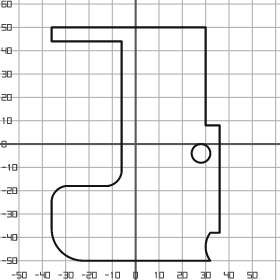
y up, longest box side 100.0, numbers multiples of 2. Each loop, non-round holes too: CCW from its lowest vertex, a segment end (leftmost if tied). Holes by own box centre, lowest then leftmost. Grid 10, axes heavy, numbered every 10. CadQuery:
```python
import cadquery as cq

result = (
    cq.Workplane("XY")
    .moveTo(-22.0, -50.0)
    .lineTo(32.0, -50.0)
    .threePointArc((30.0, -44.0), (32.0, -38.0))
    .lineTo(36.0, -38.0)
    .lineTo(36.0, 8.0)
    .lineTo(30.0, 8.0)
    .lineTo(30.0, 50.0)
    .lineTo(-36.0, 50.0)
    .lineTo(-36.0, 44.0)
    .lineTo(-6.0, 44.0)
    .lineTo(-6.0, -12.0)
    .threePointArc((-8.0, -16.0), (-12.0, -18.0))
    .lineTo(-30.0, -18.0)
    .threePointArc((-34.0, -20.0), (-36.0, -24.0))
    .lineTo(-36.0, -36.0)
    .threePointArc((-32.0, -46.0), (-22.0, -50.0))
    .close()
    .moveTo(28.0, -4.0)
    .circle(4.0)
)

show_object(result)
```